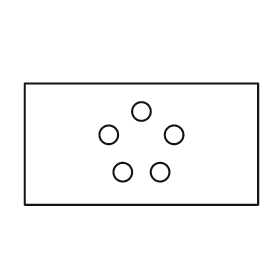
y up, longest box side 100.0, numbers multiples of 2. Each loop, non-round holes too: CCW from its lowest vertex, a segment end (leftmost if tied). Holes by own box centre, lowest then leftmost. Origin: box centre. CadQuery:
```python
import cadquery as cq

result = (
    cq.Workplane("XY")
    .moveTo(-50.0, -26.0)
    .lineTo(50.0, -26.0)
    .lineTo(50.0, 26.0)
    .lineTo(-50.0, 26.0)
    .close()
    .moveTo(-8.0, -12.0)
    .circle(4.0)
    .moveTo(8.0, -12.0)
    .circle(4.0)
    .moveTo(-14.0, 4.0)
    .circle(4.0)
    .moveTo(14.0, 4.0)
    .circle(4.0)
    .moveTo(0.0, 14.0)
    .circle(4.0)
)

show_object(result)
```